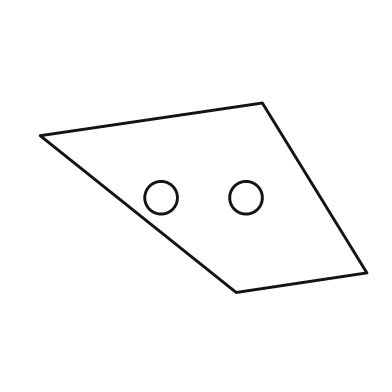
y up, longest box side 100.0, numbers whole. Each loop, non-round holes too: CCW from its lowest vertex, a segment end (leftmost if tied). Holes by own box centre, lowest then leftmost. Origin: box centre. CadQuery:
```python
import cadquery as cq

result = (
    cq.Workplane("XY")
    .moveTo(10.0, -29.0)
    .lineTo(50.0, -23.0)
    .lineTo(18.0, 29.0)
    .lineTo(-50.0, 19.0)
    .close()
    .moveTo(-13.0, 0.0)
    .circle(5.0)
    .moveTo(13.0, 0.0)
    .circle(5.0)
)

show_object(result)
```